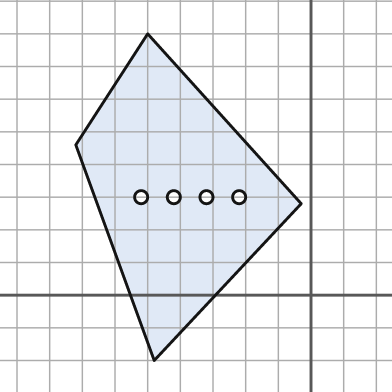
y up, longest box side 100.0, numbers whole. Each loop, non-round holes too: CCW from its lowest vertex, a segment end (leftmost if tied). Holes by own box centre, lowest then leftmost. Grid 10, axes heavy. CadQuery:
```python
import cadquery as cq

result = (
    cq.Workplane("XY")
    .moveTo(-48.0, -20.0)
    .lineTo(-3.0, 28.0)
    .lineTo(-50.0, 80.0)
    .lineTo(-72.0, 46.0)
    .close()
    .moveTo(-52.0, 30.0)
    .circle(2.0)
    .moveTo(-42.0, 30.0)
    .circle(2.0)
    .moveTo(-32.0, 30.0)
    .circle(2.0)
    .moveTo(-22.0, 30.0)
    .circle(2.0)
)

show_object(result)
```